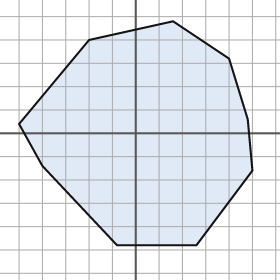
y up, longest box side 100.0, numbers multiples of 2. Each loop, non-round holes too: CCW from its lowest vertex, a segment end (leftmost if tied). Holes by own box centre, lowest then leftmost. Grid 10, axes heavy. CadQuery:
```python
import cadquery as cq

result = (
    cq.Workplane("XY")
    .moveTo(-8.0, -48.0)
    .lineTo(26.0, -48.0)
    .lineTo(50.0, -16.0)
    .lineTo(48.0, 6.0)
    .lineTo(40.0, 32.0)
    .lineTo(16.0, 48.0)
    .lineTo(-20.0, 40.0)
    .lineTo(-50.0, 4.0)
    .lineTo(-40.0, -14.0)
    .close()
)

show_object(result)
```